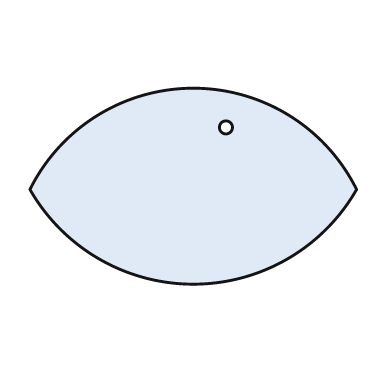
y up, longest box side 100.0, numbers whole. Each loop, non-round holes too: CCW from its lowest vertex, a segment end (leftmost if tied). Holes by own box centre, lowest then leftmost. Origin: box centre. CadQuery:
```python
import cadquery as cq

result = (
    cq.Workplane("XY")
    .moveTo(-50.0, -1.0)
    .threePointArc((0.0, -30.0), (50.0, -1.0))
    .threePointArc((0.0, 30.0), (-50.0, -1.0))
    .close()
    .moveTo(10.0, 18.0)
    .circle(2.0)
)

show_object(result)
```